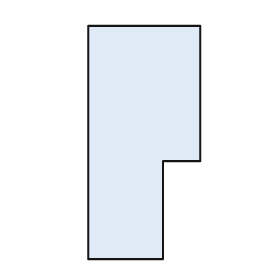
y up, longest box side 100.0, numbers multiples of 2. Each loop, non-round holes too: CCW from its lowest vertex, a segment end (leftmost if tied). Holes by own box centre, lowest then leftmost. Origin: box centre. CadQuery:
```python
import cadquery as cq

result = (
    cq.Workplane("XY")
    .moveTo(-24.0, -50.0)
    .lineTo(8.0, -50.0)
    .lineTo(8.0, -8.0)
    .lineTo(24.0, -8.0)
    .lineTo(24.0, 50.0)
    .lineTo(-24.0, 50.0)
    .close()
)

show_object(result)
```